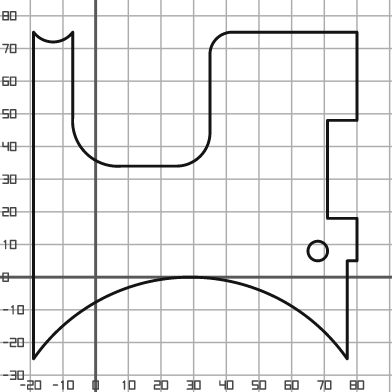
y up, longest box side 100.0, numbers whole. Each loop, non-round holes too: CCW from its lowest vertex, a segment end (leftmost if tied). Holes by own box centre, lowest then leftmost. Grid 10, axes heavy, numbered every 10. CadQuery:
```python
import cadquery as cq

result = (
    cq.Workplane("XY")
    .moveTo(-19.0, -25.0)
    .threePointArc((29.0, 0.0), (77.0, -25.0))
    .lineTo(77.0, 5.0)
    .lineTo(80.0, 5.0)
    .lineTo(80.0, 18.0)
    .lineTo(71.0, 18.0)
    .lineTo(71.0, 48.0)
    .lineTo(80.0, 48.0)
    .lineTo(80.0, 75.0)
    .lineTo(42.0, 75.0)
    .threePointArc((37.0, 73.0), (35.0, 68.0))
    .lineTo(35.0, 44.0)
    .threePointArc((32.0, 37.0), (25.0, 34.0))
    .lineTo(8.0, 34.0)
    .threePointArc((-3.0, 38.0), (-7.0, 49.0))
    .lineTo(-7.0, 75.0)
    .threePointArc((-13.0, 72.0), (-19.0, 75.0))
    .close()
    .moveTo(68.0, 8.0)
    .circle(3.0)
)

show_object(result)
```